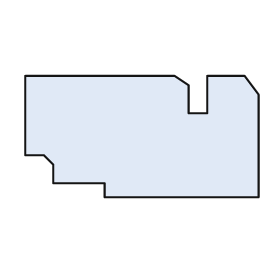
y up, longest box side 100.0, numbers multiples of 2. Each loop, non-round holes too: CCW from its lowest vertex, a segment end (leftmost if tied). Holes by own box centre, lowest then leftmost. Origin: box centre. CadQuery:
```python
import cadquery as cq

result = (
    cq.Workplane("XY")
    .moveTo(-16.0, -26.0)
    .lineTo(50.0, -26.0)
    .lineTo(50.0, 18.0)
    .lineTo(44.0, 26.0)
    .lineTo(28.0, 26.0)
    .lineTo(28.0, 10.0)
    .lineTo(20.0, 10.0)
    .lineTo(20.0, 22.0)
    .lineTo(14.0, 26.0)
    .lineTo(-50.0, 26.0)
    .lineTo(-50.0, -8.0)
    .lineTo(-42.0, -8.0)
    .lineTo(-38.0, -12.0)
    .lineTo(-38.0, -20.0)
    .lineTo(-16.0, -20.0)
    .close()
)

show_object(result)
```